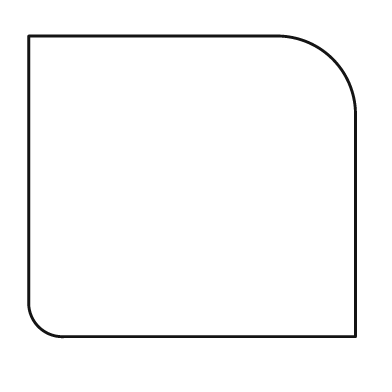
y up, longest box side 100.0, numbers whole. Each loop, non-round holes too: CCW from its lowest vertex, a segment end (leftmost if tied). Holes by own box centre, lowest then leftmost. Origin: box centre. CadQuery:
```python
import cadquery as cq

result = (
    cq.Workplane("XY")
    .moveTo(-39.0, -46.0)
    .lineTo(50.0, -46.0)
    .lineTo(50.0, 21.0)
    .threePointArc((43.0, 39.0), (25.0, 46.0))
    .lineTo(-50.0, 46.0)
    .lineTo(-50.0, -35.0)
    .threePointArc((-47.0, -43.0), (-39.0, -46.0))
    .close()
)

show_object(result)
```